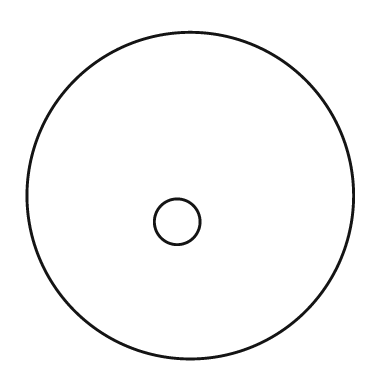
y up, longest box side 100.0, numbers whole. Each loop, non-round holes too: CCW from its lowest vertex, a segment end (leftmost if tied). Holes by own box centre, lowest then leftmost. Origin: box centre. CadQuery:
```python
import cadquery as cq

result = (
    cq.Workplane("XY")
    .moveTo(0.0, 0.0)
    .circle(50.0)
    .moveTo(-4.0, -8.0)
    .circle(7.0)
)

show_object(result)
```